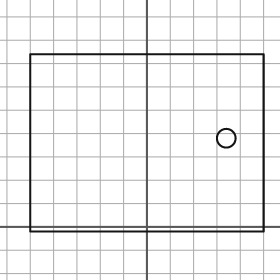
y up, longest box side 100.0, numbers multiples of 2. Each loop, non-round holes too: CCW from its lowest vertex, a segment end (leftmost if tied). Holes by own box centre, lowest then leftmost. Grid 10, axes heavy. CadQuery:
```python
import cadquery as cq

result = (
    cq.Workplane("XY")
    .moveTo(-50.0, -2.0)
    .lineTo(50.0, -2.0)
    .lineTo(50.0, 74.0)
    .lineTo(-50.0, 74.0)
    .close()
    .moveTo(34.0, 38.0)
    .circle(4.0)
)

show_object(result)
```